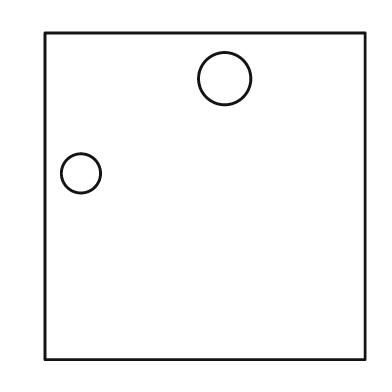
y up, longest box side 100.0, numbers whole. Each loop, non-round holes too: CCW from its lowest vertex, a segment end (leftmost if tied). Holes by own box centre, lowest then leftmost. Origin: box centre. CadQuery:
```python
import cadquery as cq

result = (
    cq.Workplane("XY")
    .moveTo(-49.0, -50.0)
    .lineTo(49.0, -50.0)
    .lineTo(49.0, 50.0)
    .lineTo(-49.0, 50.0)
    .close()
    .moveTo(-38.0, 7.0)
    .circle(6.0)
    .moveTo(6.0, 36.0)
    .circle(8.0)
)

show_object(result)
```